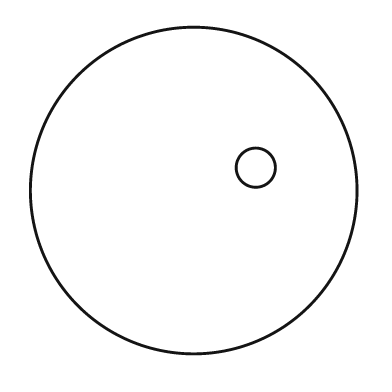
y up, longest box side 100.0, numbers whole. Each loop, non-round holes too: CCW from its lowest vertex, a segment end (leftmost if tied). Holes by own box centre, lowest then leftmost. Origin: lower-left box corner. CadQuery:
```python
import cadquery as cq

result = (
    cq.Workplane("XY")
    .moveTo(50.0, 50.0)
    .circle(50.0)
    .moveTo(69.0, 57.0)
    .circle(6.0)
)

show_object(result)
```